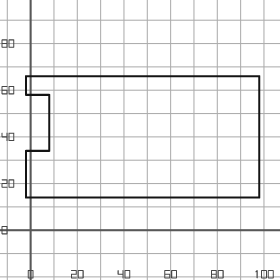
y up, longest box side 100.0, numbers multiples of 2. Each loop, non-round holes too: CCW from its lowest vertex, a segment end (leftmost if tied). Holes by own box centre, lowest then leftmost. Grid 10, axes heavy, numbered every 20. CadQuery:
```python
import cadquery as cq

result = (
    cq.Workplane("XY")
    .moveTo(-2.0, 14.0)
    .lineTo(98.0, 14.0)
    .lineTo(98.0, 66.0)
    .lineTo(-2.0, 66.0)
    .lineTo(-2.0, 58.0)
    .lineTo(8.0, 58.0)
    .lineTo(8.0, 34.0)
    .lineTo(-2.0, 34.0)
    .close()
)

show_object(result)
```